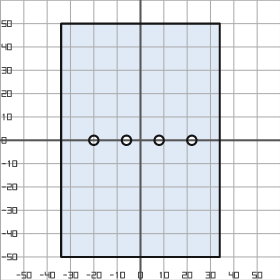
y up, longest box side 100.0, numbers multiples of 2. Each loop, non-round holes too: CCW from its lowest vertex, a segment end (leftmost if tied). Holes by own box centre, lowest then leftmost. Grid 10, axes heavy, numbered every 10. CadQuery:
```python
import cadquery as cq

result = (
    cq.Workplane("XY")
    .moveTo(-34.0, -50.0)
    .lineTo(34.0, -50.0)
    .lineTo(34.0, 50.0)
    .lineTo(-34.0, 50.0)
    .close()
    .moveTo(-20.0, 0.0)
    .circle(2.0)
    .moveTo(-6.0, 0.0)
    .circle(2.0)
    .moveTo(8.0, 0.0)
    .circle(2.0)
    .moveTo(22.0, 0.0)
    .circle(2.0)
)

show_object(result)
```